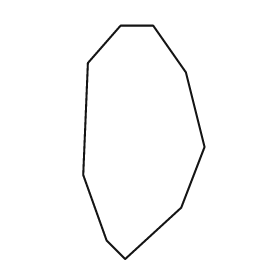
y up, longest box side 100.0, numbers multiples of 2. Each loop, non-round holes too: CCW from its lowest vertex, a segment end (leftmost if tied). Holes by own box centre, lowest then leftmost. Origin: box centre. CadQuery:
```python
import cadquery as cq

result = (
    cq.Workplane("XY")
    .moveTo(-8.0, -50.0)
    .lineTo(16.0, -28.0)
    .lineTo(26.0, -2.0)
    .lineTo(18.0, 30.0)
    .lineTo(4.0, 50.0)
    .lineTo(-10.0, 50.0)
    .lineTo(-24.0, 34.0)
    .lineTo(-26.0, -14.0)
    .lineTo(-16.0, -42.0)
    .close()
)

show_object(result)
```